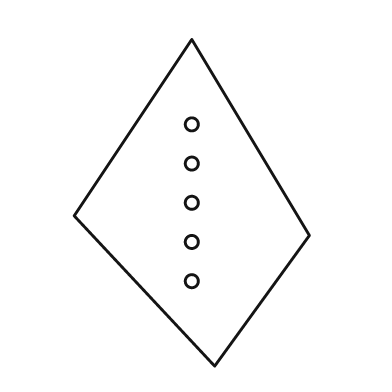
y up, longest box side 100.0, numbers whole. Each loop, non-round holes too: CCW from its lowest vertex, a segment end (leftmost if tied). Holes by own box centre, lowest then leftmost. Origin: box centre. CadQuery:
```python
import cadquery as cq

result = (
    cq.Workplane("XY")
    .moveTo(7.0, -50.0)
    .lineTo(36.0, -10.0)
    .lineTo(0.0, 50.0)
    .lineTo(-36.0, -4.0)
    .close()
    .moveTo(0.0, -24.0)
    .circle(2.0)
    .moveTo(0.0, -12.0)
    .circle(2.0)
    .moveTo(0.0, 0.0)
    .circle(2.0)
    .moveTo(0.0, 12.0)
    .circle(2.0)
    .moveTo(0.0, 24.0)
    .circle(2.0)
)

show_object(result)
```